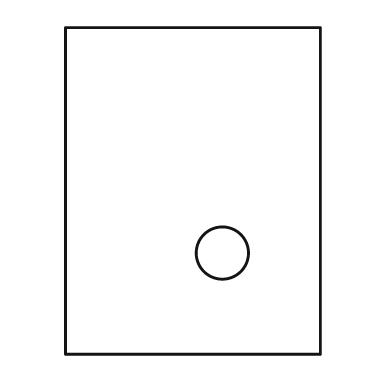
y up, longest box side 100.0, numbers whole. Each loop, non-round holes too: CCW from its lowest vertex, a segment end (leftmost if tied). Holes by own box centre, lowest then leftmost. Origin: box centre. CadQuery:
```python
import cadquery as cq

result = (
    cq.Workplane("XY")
    .moveTo(-39.0, -50.0)
    .lineTo(39.0, -50.0)
    .lineTo(39.0, 50.0)
    .lineTo(-39.0, 50.0)
    .close()
    .moveTo(9.0, -19.0)
    .circle(8.0)
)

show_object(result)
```